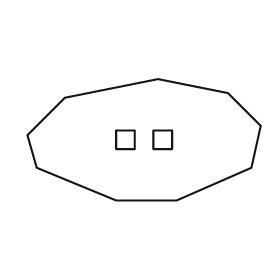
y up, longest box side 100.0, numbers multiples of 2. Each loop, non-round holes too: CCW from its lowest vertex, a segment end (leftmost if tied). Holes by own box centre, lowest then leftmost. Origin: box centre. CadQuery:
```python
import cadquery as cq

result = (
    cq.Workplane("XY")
    .moveTo(-12.0, -26.0)
    .lineTo(14.0, -26.0)
    .lineTo(46.0, -12.0)
    .lineTo(50.0, 6.0)
    .lineTo(36.0, 20.0)
    .lineTo(6.0, 26.0)
    .lineTo(-34.0, 18.0)
    .lineTo(-50.0, 2.0)
    .lineTo(-46.0, -12.0)
    .close()
    .moveTo(-12.0, -4.0)
    .lineTo(-4.0, -4.0)
    .lineTo(-4.0, 4.0)
    .lineTo(-12.0, 4.0)
    .close()
    .moveTo(4.0, -4.0)
    .lineTo(12.0, -4.0)
    .lineTo(12.0, 4.0)
    .lineTo(4.0, 4.0)
    .close()
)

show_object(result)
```